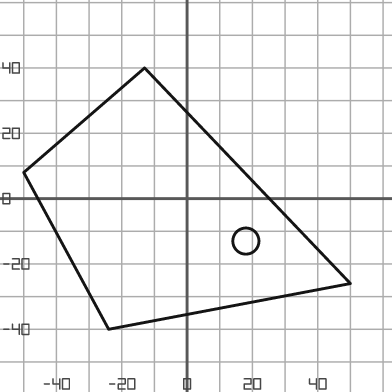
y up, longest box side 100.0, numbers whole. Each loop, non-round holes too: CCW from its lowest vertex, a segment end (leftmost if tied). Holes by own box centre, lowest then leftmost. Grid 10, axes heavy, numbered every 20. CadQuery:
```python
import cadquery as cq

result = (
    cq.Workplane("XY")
    .moveTo(-24.0, -40.0)
    .lineTo(50.0, -26.0)
    .lineTo(-13.0, 40.0)
    .lineTo(-50.0, 8.0)
    .close()
    .moveTo(18.0, -13.0)
    .circle(4.0)
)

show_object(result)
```